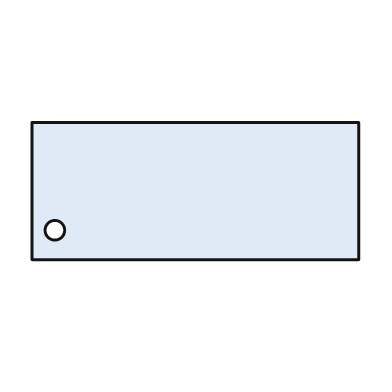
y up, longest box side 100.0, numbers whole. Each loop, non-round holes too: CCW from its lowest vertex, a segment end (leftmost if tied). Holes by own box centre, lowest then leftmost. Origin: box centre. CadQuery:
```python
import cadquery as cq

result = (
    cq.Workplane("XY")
    .moveTo(-50.0, -21.0)
    .lineTo(50.0, -21.0)
    .lineTo(50.0, 21.0)
    .lineTo(-50.0, 21.0)
    .close()
    .moveTo(-43.0, -12.0)
    .circle(3.0)
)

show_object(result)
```